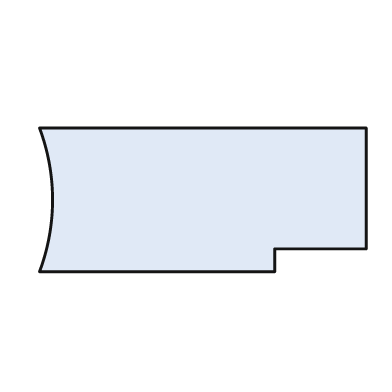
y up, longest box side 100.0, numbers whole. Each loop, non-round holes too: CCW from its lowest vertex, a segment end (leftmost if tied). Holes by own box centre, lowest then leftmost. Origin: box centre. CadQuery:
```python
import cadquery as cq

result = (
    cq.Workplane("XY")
    .moveTo(-50.0, -22.0)
    .lineTo(22.0, -22.0)
    .lineTo(22.0, -15.0)
    .lineTo(50.0, -15.0)
    .lineTo(50.0, 22.0)
    .lineTo(-50.0, 22.0)
    .threePointArc((-46.0, 0.0), (-50.0, -22.0))
    .close()
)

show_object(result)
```